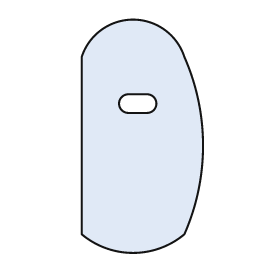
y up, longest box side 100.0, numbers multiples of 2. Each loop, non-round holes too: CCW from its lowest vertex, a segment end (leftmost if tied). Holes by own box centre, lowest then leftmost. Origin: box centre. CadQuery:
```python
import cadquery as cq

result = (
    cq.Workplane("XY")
    .moveTo(-26.0, -42.0)
    .threePointArc((-4.0, -50.0), (18.0, -42.0))
    .threePointArc((26.0, -4.0), (18.0, 34.0))
    .threePointArc((-4.0, 50.0), (-26.0, 34.0))
    .close()
    .moveTo(-6.0, 10.0)
    .lineTo(2.0, 10.0)
    .threePointArc((6.0, 14.0), (2.0, 18.0))
    .lineTo(-6.0, 18.0)
    .threePointArc((-10.0, 14.0), (-6.0, 10.0))
    .close()
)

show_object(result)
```